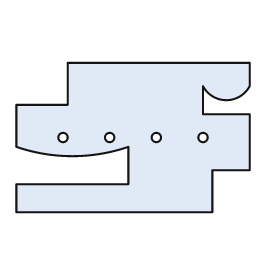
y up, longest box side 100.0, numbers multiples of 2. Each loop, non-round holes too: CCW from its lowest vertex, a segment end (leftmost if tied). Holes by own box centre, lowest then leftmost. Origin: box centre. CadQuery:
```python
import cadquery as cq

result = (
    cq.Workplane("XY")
    .moveTo(-50.0, -32.0)
    .lineTo(34.0, -32.0)
    .lineTo(34.0, -14.0)
    .lineTo(50.0, -14.0)
    .lineTo(50.0, 10.0)
    .lineTo(30.0, 10.0)
    .lineTo(30.0, 22.0)
    .threePointArc((40.0, 16.0), (50.0, 22.0))
    .lineTo(50.0, 32.0)
    .lineTo(-28.0, 32.0)
    .lineTo(-28.0, 14.0)
    .lineTo(-50.0, 14.0)
    .lineTo(-50.0, -4.0)
    .threePointArc((-26.0, -8.0), (-2.0, -4.0))
    .lineTo(-2.0, -20.0)
    .lineTo(-50.0, -20.0)
    .close()
    .moveTo(-30.0, 0.0)
    .circle(2.0)
    .moveTo(-10.0, 0.0)
    .circle(2.0)
    .moveTo(10.0, 0.0)
    .circle(2.0)
    .moveTo(30.0, 0.0)
    .circle(2.0)
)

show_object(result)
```